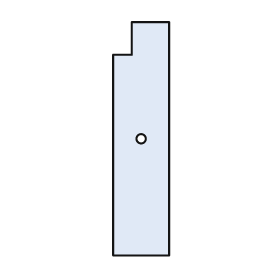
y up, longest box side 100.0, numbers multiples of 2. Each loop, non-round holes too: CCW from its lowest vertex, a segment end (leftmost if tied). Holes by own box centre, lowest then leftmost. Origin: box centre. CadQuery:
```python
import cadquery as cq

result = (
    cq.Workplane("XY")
    .moveTo(-12.0, -50.0)
    .lineTo(12.0, -50.0)
    .lineTo(12.0, 50.0)
    .lineTo(-4.0, 50.0)
    .lineTo(-4.0, 36.0)
    .lineTo(-12.0, 36.0)
    .close()
    .moveTo(0.0, 0.0)
    .circle(2.0)
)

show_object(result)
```